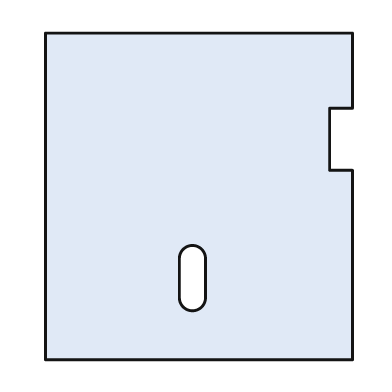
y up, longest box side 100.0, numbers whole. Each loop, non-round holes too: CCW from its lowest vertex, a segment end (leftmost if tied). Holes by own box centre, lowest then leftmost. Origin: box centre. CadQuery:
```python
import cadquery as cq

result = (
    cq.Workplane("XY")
    .moveTo(-47.0, -50.0)
    .lineTo(47.0, -50.0)
    .lineTo(47.0, 8.0)
    .lineTo(40.0, 8.0)
    .lineTo(40.0, 27.0)
    .lineTo(47.0, 27.0)
    .lineTo(47.0, 50.0)
    .lineTo(-47.0, 50.0)
    .close()
    .moveTo(-6.0, -31.0)
    .threePointArc((-2.0, -35.0), (2.0, -31.0))
    .lineTo(2.0, -19.0)
    .threePointArc((-2.0, -15.0), (-6.0, -19.0))
    .close()
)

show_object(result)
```